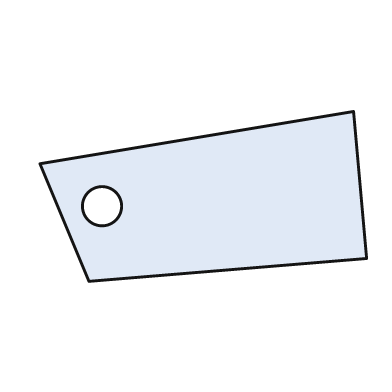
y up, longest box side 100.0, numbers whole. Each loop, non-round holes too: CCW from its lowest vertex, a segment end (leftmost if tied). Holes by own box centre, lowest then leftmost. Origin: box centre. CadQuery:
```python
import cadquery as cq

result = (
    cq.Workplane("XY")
    .moveTo(-35.0, -26.0)
    .lineTo(50.0, -19.0)
    .lineTo(46.0, 26.0)
    .lineTo(-50.0, 10.0)
    .close()
    .moveTo(-31.0, -3.0)
    .circle(6.0)
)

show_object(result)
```